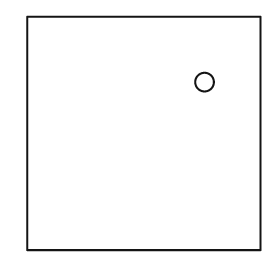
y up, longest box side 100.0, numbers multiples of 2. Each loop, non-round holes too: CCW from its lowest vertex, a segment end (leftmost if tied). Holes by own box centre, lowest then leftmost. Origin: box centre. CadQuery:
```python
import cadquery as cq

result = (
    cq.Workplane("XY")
    .moveTo(-50.0, -50.0)
    .lineTo(50.0, -50.0)
    .lineTo(50.0, 50.0)
    .lineTo(-50.0, 50.0)
    .close()
    .moveTo(26.0, 22.0)
    .circle(4.0)
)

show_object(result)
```